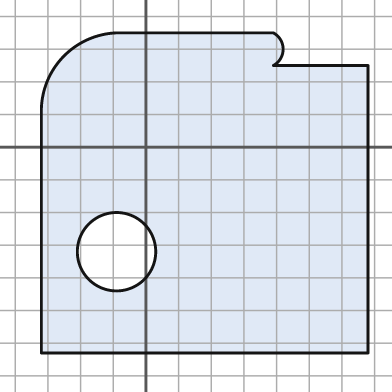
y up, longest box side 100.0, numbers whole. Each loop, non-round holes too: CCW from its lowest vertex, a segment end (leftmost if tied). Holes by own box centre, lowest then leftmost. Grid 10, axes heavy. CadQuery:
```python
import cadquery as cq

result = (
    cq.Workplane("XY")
    .moveTo(-32.0, -63.0)
    .lineTo(68.0, -63.0)
    .lineTo(68.0, 25.0)
    .lineTo(39.0, 25.0)
    .threePointArc((42.0, 30.0), (39.0, 35.0))
    .lineTo(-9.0, 35.0)
    .threePointArc((-25.0, 28.0), (-32.0, 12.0))
    .close()
    .moveTo(-9.0, -32.0)
    .circle(12.0)
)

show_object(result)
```